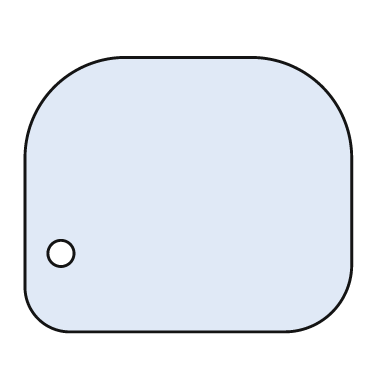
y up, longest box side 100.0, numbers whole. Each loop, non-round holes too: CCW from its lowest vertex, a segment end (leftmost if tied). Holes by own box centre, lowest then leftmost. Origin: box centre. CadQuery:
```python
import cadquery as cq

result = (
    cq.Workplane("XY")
    .moveTo(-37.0, -42.0)
    .lineTo(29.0, -42.0)
    .threePointArc((44.0, -36.0), (50.0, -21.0))
    .lineTo(50.0, 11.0)
    .threePointArc((41.0, 33.0), (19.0, 42.0))
    .lineTo(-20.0, 42.0)
    .threePointArc((-41.0, 33.0), (-50.0, 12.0))
    .lineTo(-50.0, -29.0)
    .threePointArc((-46.0, -38.0), (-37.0, -42.0))
    .close()
    .moveTo(-39.0, -18.0)
    .circle(4.0)
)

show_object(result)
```